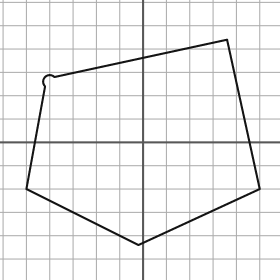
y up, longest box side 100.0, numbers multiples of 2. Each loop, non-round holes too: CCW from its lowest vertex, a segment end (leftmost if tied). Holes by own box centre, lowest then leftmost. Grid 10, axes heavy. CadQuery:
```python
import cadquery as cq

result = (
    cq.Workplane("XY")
    .moveTo(-2.0, -44.0)
    .lineTo(50.0, -20.0)
    .lineTo(36.0, 44.0)
    .lineTo(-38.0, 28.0)
    .threePointArc((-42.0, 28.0), (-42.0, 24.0))
    .lineTo(-50.0, -20.0)
    .close()
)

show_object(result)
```